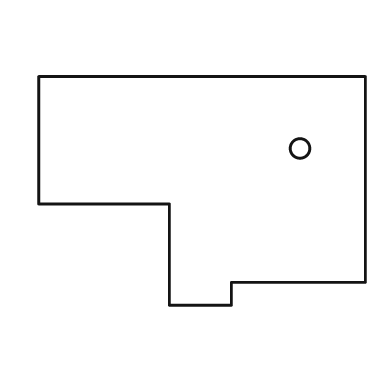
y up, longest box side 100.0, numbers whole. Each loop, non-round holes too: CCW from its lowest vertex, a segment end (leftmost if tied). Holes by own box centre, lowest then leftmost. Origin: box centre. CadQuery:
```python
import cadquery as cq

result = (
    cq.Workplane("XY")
    .moveTo(-10.0, -35.0)
    .lineTo(9.0, -35.0)
    .lineTo(9.0, -28.0)
    .lineTo(50.0, -28.0)
    .lineTo(50.0, 35.0)
    .lineTo(-50.0, 35.0)
    .lineTo(-50.0, -4.0)
    .lineTo(-10.0, -4.0)
    .close()
    .moveTo(30.0, 13.0)
    .circle(3.0)
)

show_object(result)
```